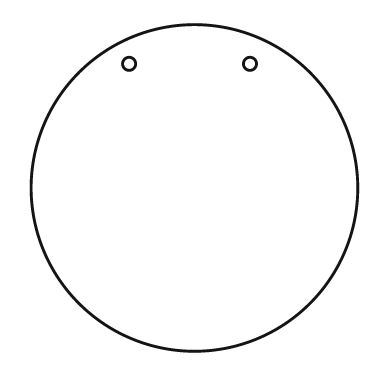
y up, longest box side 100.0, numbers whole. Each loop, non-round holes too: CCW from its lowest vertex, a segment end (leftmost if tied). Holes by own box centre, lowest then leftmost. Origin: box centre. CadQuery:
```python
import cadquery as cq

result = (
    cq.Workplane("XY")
    .moveTo(0.0, 0.0)
    .circle(50.0)
    .moveTo(-20.0, 38.0)
    .circle(2.0)
    .moveTo(17.0, 38.0)
    .circle(2.0)
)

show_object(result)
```